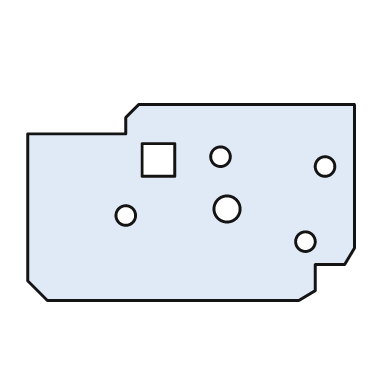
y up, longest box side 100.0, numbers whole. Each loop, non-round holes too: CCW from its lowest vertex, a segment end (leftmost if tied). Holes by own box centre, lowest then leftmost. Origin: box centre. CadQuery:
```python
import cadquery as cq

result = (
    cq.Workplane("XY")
    .moveTo(-44.0, -30.0)
    .lineTo(33.0, -30.0)
    .lineTo(38.0, -27.0)
    .lineTo(38.0, -19.0)
    .lineTo(47.0, -19.0)
    .lineTo(50.0, -14.0)
    .lineTo(50.0, 30.0)
    .lineTo(-16.0, 30.0)
    .lineTo(-20.0, 26.0)
    .lineTo(-20.0, 21.0)
    .lineTo(-50.0, 21.0)
    .lineTo(-50.0, -24.0)
    .close()
    .moveTo(35.0, -12.0)
    .circle(3.0)
    .moveTo(-20.0, -4.0)
    .circle(3.0)
    .moveTo(11.0, -2.0)
    .circle(4.0)
    .moveTo(41.0, 11.0)
    .circle(3.0)
    .moveTo(-15.0, 8.0)
    .lineTo(-5.0, 8.0)
    .lineTo(-5.0, 18.0)
    .lineTo(-15.0, 18.0)
    .close()
    .moveTo(9.0, 14.0)
    .circle(3.0)
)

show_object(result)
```